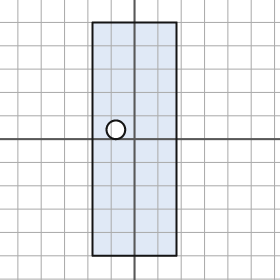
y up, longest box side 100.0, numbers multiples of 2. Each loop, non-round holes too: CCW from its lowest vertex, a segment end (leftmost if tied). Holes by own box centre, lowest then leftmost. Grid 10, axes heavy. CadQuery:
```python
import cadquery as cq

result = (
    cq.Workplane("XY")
    .moveTo(-18.0, -50.0)
    .lineTo(18.0, -50.0)
    .lineTo(18.0, 50.0)
    .lineTo(-18.0, 50.0)
    .close()
    .moveTo(-8.0, 4.0)
    .circle(4.0)
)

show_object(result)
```